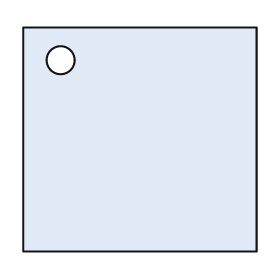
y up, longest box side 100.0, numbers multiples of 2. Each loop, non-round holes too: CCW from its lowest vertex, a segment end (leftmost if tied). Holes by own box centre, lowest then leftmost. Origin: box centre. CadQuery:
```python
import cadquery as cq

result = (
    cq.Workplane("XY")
    .moveTo(-50.0, -48.0)
    .lineTo(50.0, -48.0)
    .lineTo(50.0, 48.0)
    .lineTo(-50.0, 48.0)
    .close()
    .moveTo(-34.0, 34.0)
    .circle(6.0)
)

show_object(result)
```